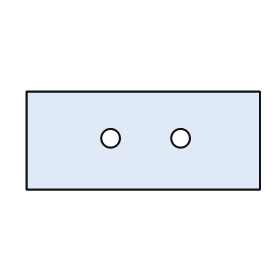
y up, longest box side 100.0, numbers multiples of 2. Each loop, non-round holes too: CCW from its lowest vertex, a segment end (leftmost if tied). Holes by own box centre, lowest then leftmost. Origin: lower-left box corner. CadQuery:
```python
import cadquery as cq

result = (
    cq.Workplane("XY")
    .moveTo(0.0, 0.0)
    .lineTo(100.0, 0.0)
    .lineTo(100.0, 42.0)
    .lineTo(0.0, 42.0)
    .close()
    .moveTo(36.0, 22.0)
    .circle(4.0)
    .moveTo(66.0, 22.0)
    .circle(4.0)
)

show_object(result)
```